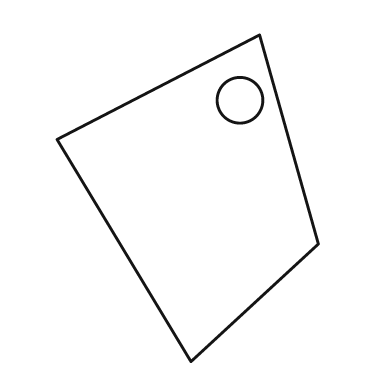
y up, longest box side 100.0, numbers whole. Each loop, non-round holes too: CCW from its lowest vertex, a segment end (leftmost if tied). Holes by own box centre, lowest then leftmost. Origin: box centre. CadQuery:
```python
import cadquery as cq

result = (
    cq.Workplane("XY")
    .moveTo(1.0, -50.0)
    .lineTo(40.0, -14.0)
    .lineTo(22.0, 50.0)
    .lineTo(-40.0, 18.0)
    .close()
    .moveTo(16.0, 30.0)
    .circle(7.0)
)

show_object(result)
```